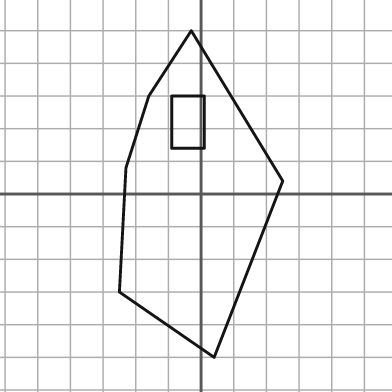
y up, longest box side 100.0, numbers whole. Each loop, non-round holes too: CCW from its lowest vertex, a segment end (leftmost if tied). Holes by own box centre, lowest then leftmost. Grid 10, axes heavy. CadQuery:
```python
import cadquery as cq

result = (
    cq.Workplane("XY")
    .moveTo(4.0, -50.0)
    .lineTo(25.0, 4.0)
    .lineTo(-3.0, 50.0)
    .lineTo(-16.0, 30.0)
    .lineTo(-23.0, 8.0)
    .lineTo(-25.0, -30.0)
    .close()
    .moveTo(-9.0, 14.0)
    .lineTo(1.0, 14.0)
    .lineTo(1.0, 30.0)
    .lineTo(-9.0, 30.0)
    .close()
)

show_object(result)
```